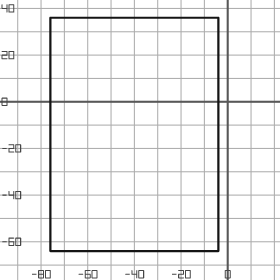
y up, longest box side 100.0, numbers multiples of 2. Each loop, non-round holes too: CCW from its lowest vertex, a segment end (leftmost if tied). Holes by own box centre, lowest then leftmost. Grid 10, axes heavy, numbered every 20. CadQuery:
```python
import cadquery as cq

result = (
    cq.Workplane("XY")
    .moveTo(-76.0, -64.0)
    .lineTo(-4.0, -64.0)
    .lineTo(-4.0, 36.0)
    .lineTo(-76.0, 36.0)
    .close()
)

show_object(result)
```